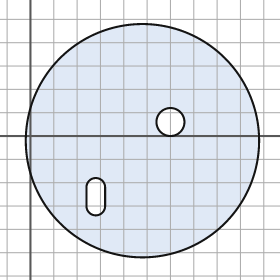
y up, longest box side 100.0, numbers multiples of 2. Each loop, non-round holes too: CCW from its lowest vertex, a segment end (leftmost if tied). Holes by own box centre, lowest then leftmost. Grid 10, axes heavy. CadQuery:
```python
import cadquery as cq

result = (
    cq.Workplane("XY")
    .moveTo(48.0, -2.0)
    .circle(50.0)
    .moveTo(24.0, -30.0)
    .threePointArc((28.0, -34.0), (32.0, -30.0))
    .lineTo(32.0, -22.0)
    .threePointArc((28.0, -18.0), (24.0, -22.0))
    .close()
    .moveTo(60.0, 6.0)
    .circle(6.0)
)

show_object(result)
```